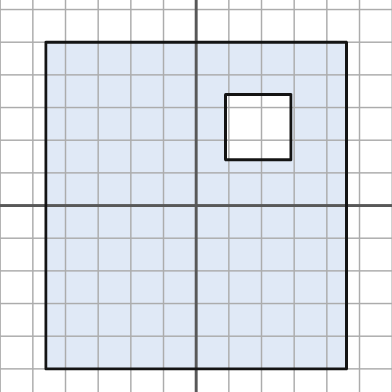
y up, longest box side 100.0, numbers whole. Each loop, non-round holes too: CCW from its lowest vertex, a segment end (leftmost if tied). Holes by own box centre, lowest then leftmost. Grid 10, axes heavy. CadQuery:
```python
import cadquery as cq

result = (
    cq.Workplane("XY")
    .moveTo(-46.0, -50.0)
    .lineTo(46.0, -50.0)
    .lineTo(46.0, 50.0)
    .lineTo(-46.0, 50.0)
    .close()
    .moveTo(9.0, 14.0)
    .lineTo(29.0, 14.0)
    .lineTo(29.0, 34.0)
    .lineTo(9.0, 34.0)
    .close()
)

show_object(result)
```